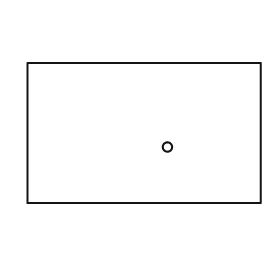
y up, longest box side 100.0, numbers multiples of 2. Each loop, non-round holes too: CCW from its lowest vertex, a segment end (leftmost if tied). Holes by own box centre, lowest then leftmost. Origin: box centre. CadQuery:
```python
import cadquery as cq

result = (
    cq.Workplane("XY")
    .moveTo(-50.0, -30.0)
    .lineTo(50.0, -30.0)
    .lineTo(50.0, 30.0)
    .lineTo(-50.0, 30.0)
    .close()
    .moveTo(10.0, -6.0)
    .circle(2.0)
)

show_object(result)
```